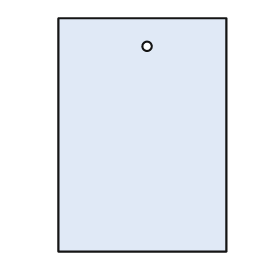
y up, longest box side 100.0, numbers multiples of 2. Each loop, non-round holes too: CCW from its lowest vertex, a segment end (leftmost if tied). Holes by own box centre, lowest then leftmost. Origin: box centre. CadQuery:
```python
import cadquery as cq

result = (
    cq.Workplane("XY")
    .moveTo(-36.0, -50.0)
    .lineTo(36.0, -50.0)
    .lineTo(36.0, 50.0)
    .lineTo(-36.0, 50.0)
    .close()
    .moveTo(2.0, 38.0)
    .circle(2.0)
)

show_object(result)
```